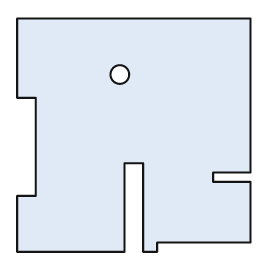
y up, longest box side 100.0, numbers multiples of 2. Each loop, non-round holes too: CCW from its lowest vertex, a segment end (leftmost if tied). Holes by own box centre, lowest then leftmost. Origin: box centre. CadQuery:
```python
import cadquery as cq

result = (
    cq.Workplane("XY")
    .moveTo(-50.0, -50.0)
    .lineTo(-4.0, -50.0)
    .lineTo(-4.0, -12.0)
    .lineTo(4.0, -12.0)
    .lineTo(4.0, -50.0)
    .lineTo(10.0, -50.0)
    .lineTo(10.0, -46.0)
    .lineTo(50.0, -46.0)
    .lineTo(50.0, -20.0)
    .lineTo(34.0, -20.0)
    .lineTo(34.0, -16.0)
    .lineTo(50.0, -16.0)
    .lineTo(50.0, 50.0)
    .lineTo(-50.0, 50.0)
    .lineTo(-50.0, 16.0)
    .lineTo(-42.0, 16.0)
    .lineTo(-42.0, -26.0)
    .lineTo(-50.0, -26.0)
    .close()
    .moveTo(-6.0, 26.0)
    .circle(4.0)
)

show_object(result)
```